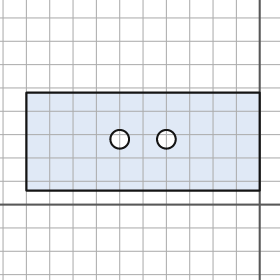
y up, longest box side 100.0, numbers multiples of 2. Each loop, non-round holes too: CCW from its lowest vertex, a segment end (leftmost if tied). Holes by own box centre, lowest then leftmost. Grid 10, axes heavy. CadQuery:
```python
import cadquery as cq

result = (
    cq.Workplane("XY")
    .moveTo(-100.0, 6.0)
    .lineTo(0.0, 6.0)
    .lineTo(0.0, 48.0)
    .lineTo(-100.0, 48.0)
    .close()
    .moveTo(-60.0, 28.0)
    .circle(4.0)
    .moveTo(-40.0, 28.0)
    .circle(4.0)
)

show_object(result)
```